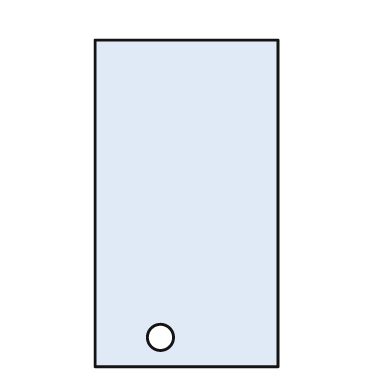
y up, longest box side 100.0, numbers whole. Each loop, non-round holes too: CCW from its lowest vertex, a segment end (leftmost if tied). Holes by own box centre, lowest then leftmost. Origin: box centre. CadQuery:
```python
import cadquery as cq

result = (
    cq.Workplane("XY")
    .moveTo(-28.0, -50.0)
    .lineTo(28.0, -50.0)
    .lineTo(28.0, 50.0)
    .lineTo(-28.0, 50.0)
    .close()
    .moveTo(-8.0, -41.0)
    .circle(4.0)
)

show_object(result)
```